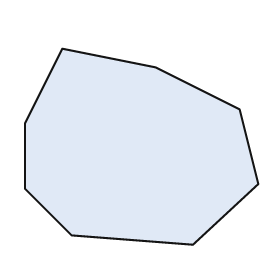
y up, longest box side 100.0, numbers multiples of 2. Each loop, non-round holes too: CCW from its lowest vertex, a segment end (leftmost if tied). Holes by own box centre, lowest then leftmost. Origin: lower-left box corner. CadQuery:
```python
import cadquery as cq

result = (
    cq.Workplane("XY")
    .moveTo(72.0, 0.0)
    .lineTo(100.0, 26.0)
    .lineTo(92.0, 58.0)
    .lineTo(56.0, 76.0)
    .lineTo(16.0, 84.0)
    .lineTo(0.0, 52.0)
    .lineTo(0.0, 24.0)
    .lineTo(20.0, 4.0)
    .close()
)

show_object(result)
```